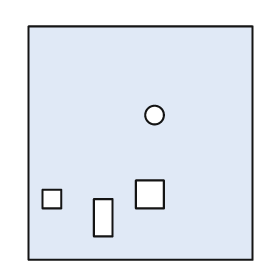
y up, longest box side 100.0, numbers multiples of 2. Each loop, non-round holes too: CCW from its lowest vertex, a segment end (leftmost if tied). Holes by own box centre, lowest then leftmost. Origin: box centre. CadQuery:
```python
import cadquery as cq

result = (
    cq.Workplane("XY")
    .moveTo(-48.0, -50.0)
    .lineTo(48.0, -50.0)
    .lineTo(48.0, 50.0)
    .lineTo(-48.0, 50.0)
    .close()
    .moveTo(-20.0, -40.0)
    .lineTo(-12.0, -40.0)
    .lineTo(-12.0, -24.0)
    .lineTo(-20.0, -24.0)
    .close()
    .moveTo(-42.0, -28.0)
    .lineTo(-34.0, -28.0)
    .lineTo(-34.0, -20.0)
    .lineTo(-42.0, -20.0)
    .close()
    .moveTo(-2.0, -28.0)
    .lineTo(10.0, -28.0)
    .lineTo(10.0, -16.0)
    .lineTo(-2.0, -16.0)
    .close()
    .moveTo(6.0, 12.0)
    .circle(4.0)
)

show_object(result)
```